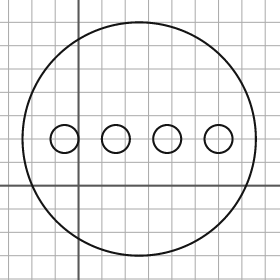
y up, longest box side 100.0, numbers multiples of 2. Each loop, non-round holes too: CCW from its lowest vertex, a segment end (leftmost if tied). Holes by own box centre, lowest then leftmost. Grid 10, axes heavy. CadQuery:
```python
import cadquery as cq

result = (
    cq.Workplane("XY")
    .moveTo(26.0, 20.0)
    .circle(50.0)
    .moveTo(-6.0, 20.0)
    .circle(6.0)
    .moveTo(16.0, 20.0)
    .circle(6.0)
    .moveTo(38.0, 20.0)
    .circle(6.0)
    .moveTo(60.0, 20.0)
    .circle(6.0)
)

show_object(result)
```